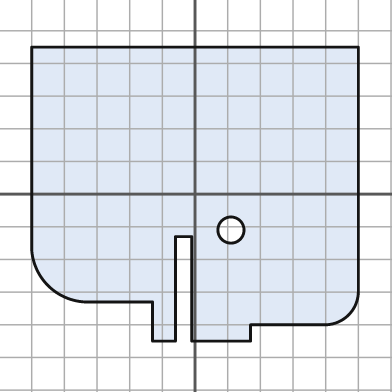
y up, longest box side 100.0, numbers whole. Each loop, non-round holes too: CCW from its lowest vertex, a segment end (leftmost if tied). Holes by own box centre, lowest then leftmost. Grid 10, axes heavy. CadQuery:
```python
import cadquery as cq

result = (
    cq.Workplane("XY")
    .moveTo(-13.0, -45.0)
    .lineTo(-6.0, -45.0)
    .lineTo(-6.0, -13.0)
    .lineTo(-1.0, -13.0)
    .lineTo(-1.0, -45.0)
    .lineTo(17.0, -45.0)
    .lineTo(17.0, -40.0)
    .lineTo(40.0, -40.0)
    .threePointArc((47.0, -37.0), (50.0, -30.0))
    .lineTo(50.0, 45.0)
    .lineTo(-50.0, 45.0)
    .lineTo(-50.0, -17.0)
    .threePointArc((-45.0, -28.0), (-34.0, -33.0))
    .lineTo(-13.0, -33.0)
    .close()
    .moveTo(11.0, -11.0)
    .circle(4.0)
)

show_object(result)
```